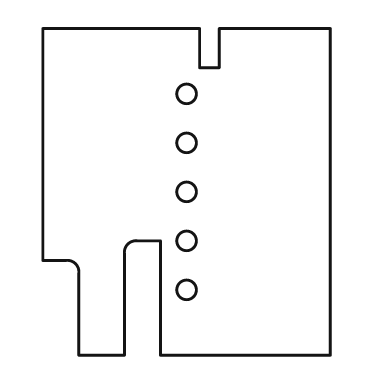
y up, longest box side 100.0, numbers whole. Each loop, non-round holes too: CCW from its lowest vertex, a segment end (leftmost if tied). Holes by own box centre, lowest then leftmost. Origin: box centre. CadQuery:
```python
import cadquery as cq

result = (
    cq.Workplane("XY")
    .moveTo(-33.0, -50.0)
    .lineTo(-19.0, -50.0)
    .lineTo(-19.0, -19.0)
    .threePointArc((-18.0, -16.0), (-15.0, -15.0))
    .lineTo(-8.0, -15.0)
    .lineTo(-8.0, -50.0)
    .lineTo(44.0, -50.0)
    .lineTo(44.0, 50.0)
    .lineTo(10.0, 50.0)
    .lineTo(10.0, 38.0)
    .lineTo(4.0, 38.0)
    .lineTo(4.0, 50.0)
    .lineTo(-44.0, 50.0)
    .lineTo(-44.0, -21.0)
    .lineTo(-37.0, -21.0)
    .threePointArc((-34.0, -22.0), (-33.0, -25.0))
    .close()
    .moveTo(0.0, -30.0)
    .circle(3.0)
    .moveTo(0.0, -15.0)
    .circle(3.0)
    .moveTo(0.0, 0.0)
    .circle(3.0)
    .moveTo(0.0, 15.0)
    .circle(3.0)
    .moveTo(0.0, 30.0)
    .circle(3.0)
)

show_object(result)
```